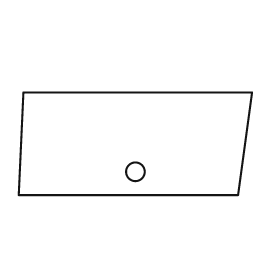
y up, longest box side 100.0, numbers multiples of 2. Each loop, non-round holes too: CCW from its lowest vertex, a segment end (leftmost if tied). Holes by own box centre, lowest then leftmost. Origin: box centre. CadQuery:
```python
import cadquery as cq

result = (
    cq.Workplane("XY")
    .moveTo(-50.0, -22.0)
    .lineTo(44.0, -22.0)
    .lineTo(50.0, 22.0)
    .lineTo(-48.0, 22.0)
    .close()
    .moveTo(0.0, -12.0)
    .circle(4.0)
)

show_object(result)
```